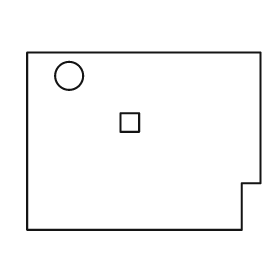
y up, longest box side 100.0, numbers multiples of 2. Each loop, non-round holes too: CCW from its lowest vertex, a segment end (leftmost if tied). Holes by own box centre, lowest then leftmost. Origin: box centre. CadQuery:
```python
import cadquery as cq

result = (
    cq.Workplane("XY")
    .moveTo(-50.0, -38.0)
    .lineTo(42.0, -38.0)
    .lineTo(42.0, -18.0)
    .lineTo(50.0, -18.0)
    .lineTo(50.0, 38.0)
    .lineTo(-50.0, 38.0)
    .close()
    .moveTo(-10.0, 4.0)
    .lineTo(-2.0, 4.0)
    .lineTo(-2.0, 12.0)
    .lineTo(-10.0, 12.0)
    .close()
    .moveTo(-32.0, 28.0)
    .circle(6.0)
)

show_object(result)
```